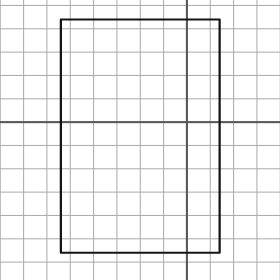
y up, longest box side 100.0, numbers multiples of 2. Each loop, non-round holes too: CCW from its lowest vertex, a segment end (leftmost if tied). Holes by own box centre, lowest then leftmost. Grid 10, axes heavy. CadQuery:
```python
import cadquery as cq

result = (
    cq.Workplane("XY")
    .moveTo(-54.0, -56.0)
    .lineTo(14.0, -56.0)
    .lineTo(14.0, 44.0)
    .lineTo(-54.0, 44.0)
    .close()
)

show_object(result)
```